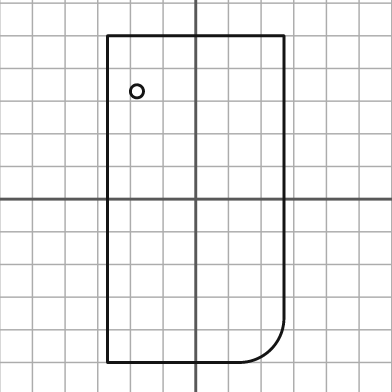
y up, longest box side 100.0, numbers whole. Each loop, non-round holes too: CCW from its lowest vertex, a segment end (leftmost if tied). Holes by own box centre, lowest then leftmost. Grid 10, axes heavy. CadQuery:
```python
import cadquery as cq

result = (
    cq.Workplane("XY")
    .moveTo(-27.0, -50.0)
    .lineTo(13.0, -50.0)
    .threePointArc((23.0, -46.0), (27.0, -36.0))
    .lineTo(27.0, 50.0)
    .lineTo(-27.0, 50.0)
    .close()
    .moveTo(-18.0, 33.0)
    .circle(2.0)
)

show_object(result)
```